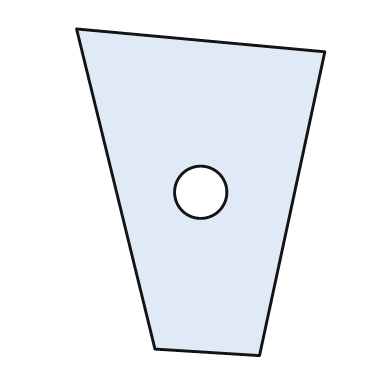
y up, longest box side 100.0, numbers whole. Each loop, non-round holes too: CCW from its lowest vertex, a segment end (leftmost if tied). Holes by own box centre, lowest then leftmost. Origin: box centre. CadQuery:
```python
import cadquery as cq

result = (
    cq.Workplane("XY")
    .moveTo(18.0, -50.0)
    .lineTo(38.0, 43.0)
    .lineTo(-38.0, 50.0)
    .lineTo(-14.0, -48.0)
    .close()
    .moveTo(0.0, 0.0)
    .circle(8.0)
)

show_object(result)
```